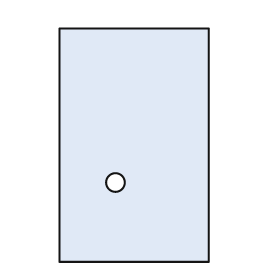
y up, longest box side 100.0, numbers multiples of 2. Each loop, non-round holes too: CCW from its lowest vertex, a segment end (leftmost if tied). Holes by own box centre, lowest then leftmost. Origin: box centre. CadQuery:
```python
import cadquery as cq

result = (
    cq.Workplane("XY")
    .moveTo(-32.0, -50.0)
    .lineTo(32.0, -50.0)
    .lineTo(32.0, 50.0)
    .lineTo(-32.0, 50.0)
    .close()
    .moveTo(-8.0, -16.0)
    .circle(4.0)
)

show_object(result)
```